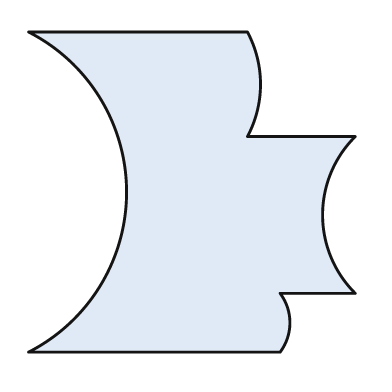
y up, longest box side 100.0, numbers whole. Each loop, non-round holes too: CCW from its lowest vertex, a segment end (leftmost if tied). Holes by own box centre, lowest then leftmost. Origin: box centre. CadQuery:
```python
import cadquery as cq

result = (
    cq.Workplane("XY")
    .moveTo(-50.0, -49.0)
    .lineTo(27.0, -49.0)
    .threePointArc((30.0, -40.0), (27.0, -31.0))
    .lineTo(50.0, -31.0)
    .threePointArc((40.0, -7.0), (50.0, 17.0))
    .lineTo(17.0, 17.0)
    .threePointArc((21.0, 33.0), (17.0, 49.0))
    .lineTo(-50.0, 49.0)
    .threePointArc((-20.0, 0.0), (-50.0, -49.0))
    .close()
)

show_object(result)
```